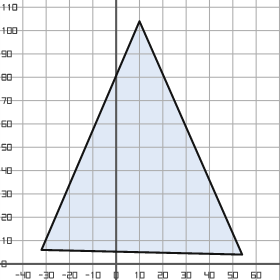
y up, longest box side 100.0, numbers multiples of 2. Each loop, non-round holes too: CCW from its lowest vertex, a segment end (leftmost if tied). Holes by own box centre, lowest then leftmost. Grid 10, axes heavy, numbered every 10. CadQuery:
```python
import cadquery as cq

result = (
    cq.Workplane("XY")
    .moveTo(54.0, 4.0)
    .lineTo(10.0, 104.0)
    .lineTo(-32.0, 6.0)
    .close()
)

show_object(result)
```